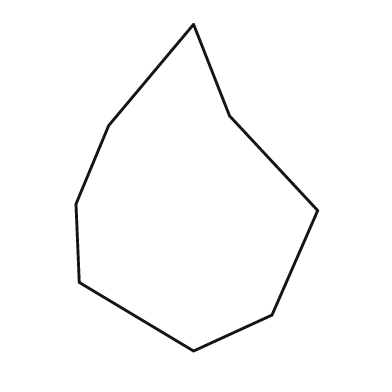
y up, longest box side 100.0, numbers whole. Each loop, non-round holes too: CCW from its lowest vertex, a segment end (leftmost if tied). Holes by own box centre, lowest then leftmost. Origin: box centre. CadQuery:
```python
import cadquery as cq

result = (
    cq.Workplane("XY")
    .moveTo(-1.0, -50.0)
    .lineTo(23.0, -39.0)
    .lineTo(37.0, -7.0)
    .lineTo(10.0, 22.0)
    .lineTo(-1.0, 50.0)
    .lineTo(-27.0, 19.0)
    .lineTo(-37.0, -5.0)
    .lineTo(-36.0, -29.0)
    .close()
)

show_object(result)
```